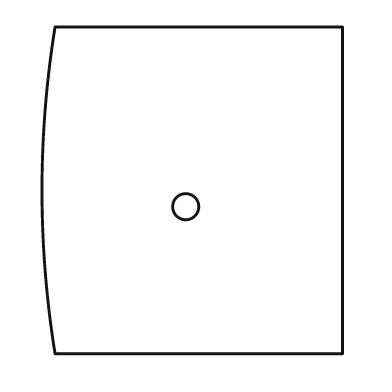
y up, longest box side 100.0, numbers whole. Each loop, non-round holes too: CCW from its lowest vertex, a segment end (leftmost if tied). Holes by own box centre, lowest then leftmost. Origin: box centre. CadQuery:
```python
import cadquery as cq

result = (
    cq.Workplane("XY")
    .moveTo(-42.0, -50.0)
    .lineTo(46.0, -50.0)
    .lineTo(46.0, 50.0)
    .lineTo(-42.0, 50.0)
    .threePointArc((-46.0, 0.0), (-42.0, -50.0))
    .close()
    .moveTo(-2.0, -5.0)
    .circle(4.0)
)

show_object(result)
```